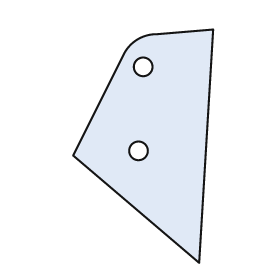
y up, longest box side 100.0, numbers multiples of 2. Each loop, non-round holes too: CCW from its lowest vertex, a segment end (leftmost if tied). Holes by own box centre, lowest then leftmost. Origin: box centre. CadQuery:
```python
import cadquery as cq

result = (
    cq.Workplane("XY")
    .moveTo(24.0, -50.0)
    .lineTo(30.0, 50.0)
    .lineTo(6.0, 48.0)
    .threePointArc((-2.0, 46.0), (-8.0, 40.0))
    .lineTo(-30.0, -4.0)
    .close()
    .moveTo(-2.0, -2.0)
    .circle(4.0)
    .moveTo(0.0, 34.0)
    .circle(4.0)
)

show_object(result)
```